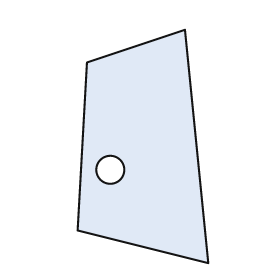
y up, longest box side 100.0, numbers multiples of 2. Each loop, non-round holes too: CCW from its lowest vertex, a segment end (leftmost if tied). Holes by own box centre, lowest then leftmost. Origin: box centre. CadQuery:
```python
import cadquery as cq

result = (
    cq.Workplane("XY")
    .moveTo(28.0, -50.0)
    .lineTo(18.0, 50.0)
    .lineTo(-24.0, 36.0)
    .lineTo(-28.0, -36.0)
    .close()
    .moveTo(-14.0, -10.0)
    .circle(6.0)
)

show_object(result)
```